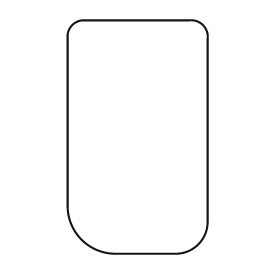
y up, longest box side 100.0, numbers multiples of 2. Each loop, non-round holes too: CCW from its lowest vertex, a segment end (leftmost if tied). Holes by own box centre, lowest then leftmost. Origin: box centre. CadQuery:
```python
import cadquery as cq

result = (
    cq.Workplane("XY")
    .moveTo(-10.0, -50.0)
    .lineTo(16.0, -50.0)
    .threePointArc((26.0, -46.0), (30.0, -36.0))
    .lineTo(30.0, 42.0)
    .threePointArc((28.0, 48.0), (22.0, 50.0))
    .lineTo(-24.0, 50.0)
    .threePointArc((-28.0, 48.0), (-30.0, 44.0))
    .lineTo(-30.0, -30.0)
    .threePointArc((-24.0, -44.0), (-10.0, -50.0))
    .close()
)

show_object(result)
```